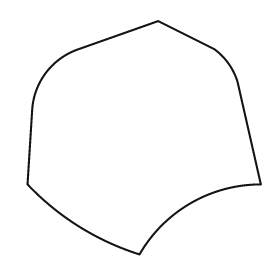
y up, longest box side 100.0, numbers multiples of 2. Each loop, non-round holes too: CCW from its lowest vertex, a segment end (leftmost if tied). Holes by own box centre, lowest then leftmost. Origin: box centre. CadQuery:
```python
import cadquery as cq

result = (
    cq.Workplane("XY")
    .moveTo(-2.0, -50.0)
    .threePointArc((20.0, -28.0), (50.0, -20.0))
    .lineTo(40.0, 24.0)
    .threePointArc((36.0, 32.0), (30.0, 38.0))
    .lineTo(6.0, 50.0)
    .lineTo(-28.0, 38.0)
    .threePointArc((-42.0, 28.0), (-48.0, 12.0))
    .lineTo(-50.0, -20.0)
    .threePointArc((-28.0, -38.0), (-2.0, -50.0))
    .close()
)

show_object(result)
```